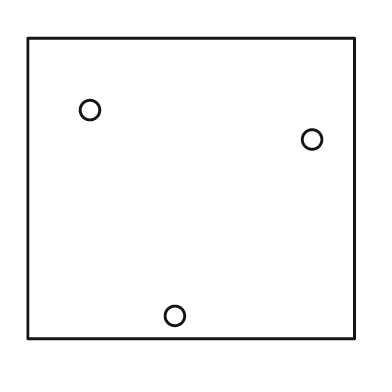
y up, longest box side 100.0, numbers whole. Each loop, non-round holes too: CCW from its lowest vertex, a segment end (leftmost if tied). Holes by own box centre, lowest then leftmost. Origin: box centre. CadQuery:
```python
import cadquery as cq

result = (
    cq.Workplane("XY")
    .moveTo(-50.0, -46.0)
    .lineTo(50.0, -46.0)
    .lineTo(50.0, 46.0)
    .lineTo(-50.0, 46.0)
    .close()
    .moveTo(-5.0, -39.0)
    .circle(3.0)
    .moveTo(37.0, 15.0)
    .circle(3.0)
    .moveTo(-31.0, 24.0)
    .circle(3.0)
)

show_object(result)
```